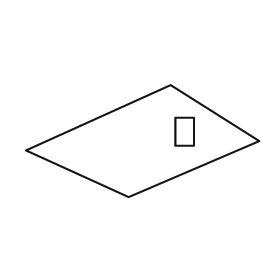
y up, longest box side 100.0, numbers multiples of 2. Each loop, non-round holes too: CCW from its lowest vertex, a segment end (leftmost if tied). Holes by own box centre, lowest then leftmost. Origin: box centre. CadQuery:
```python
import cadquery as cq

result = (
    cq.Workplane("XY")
    .moveTo(-6.0, -24.0)
    .lineTo(50.0, 0.0)
    .lineTo(12.0, 24.0)
    .lineTo(-50.0, -4.0)
    .close()
    .moveTo(14.0, -2.0)
    .lineTo(22.0, -2.0)
    .lineTo(22.0, 10.0)
    .lineTo(14.0, 10.0)
    .close()
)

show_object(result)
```